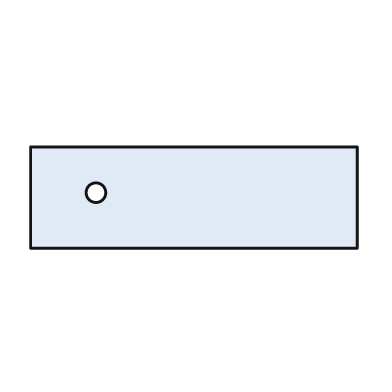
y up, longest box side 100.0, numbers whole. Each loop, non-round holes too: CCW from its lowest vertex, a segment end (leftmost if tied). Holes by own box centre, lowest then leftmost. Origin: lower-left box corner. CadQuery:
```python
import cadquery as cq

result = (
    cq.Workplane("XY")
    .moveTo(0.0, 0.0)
    .lineTo(100.0, 0.0)
    .lineTo(100.0, 31.0)
    .lineTo(0.0, 31.0)
    .close()
    .moveTo(20.0, 17.0)
    .circle(3.0)
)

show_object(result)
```